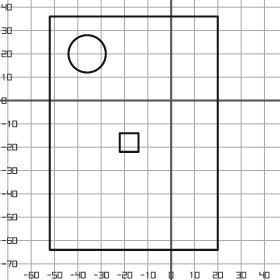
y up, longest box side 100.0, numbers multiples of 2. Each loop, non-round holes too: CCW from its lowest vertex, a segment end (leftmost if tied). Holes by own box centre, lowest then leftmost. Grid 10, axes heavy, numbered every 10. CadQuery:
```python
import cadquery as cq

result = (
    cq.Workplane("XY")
    .moveTo(-52.0, -64.0)
    .lineTo(20.0, -64.0)
    .lineTo(20.0, 36.0)
    .lineTo(-52.0, 36.0)
    .close()
    .moveTo(-22.0, -22.0)
    .lineTo(-14.0, -22.0)
    .lineTo(-14.0, -14.0)
    .lineTo(-22.0, -14.0)
    .close()
    .moveTo(-36.0, 20.0)
    .circle(8.0)
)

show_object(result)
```